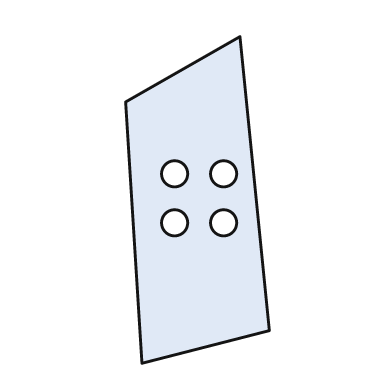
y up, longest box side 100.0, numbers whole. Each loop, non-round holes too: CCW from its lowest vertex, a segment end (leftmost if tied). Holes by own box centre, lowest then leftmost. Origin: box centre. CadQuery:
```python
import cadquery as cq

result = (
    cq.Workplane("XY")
    .moveTo(-17.0, -50.0)
    .lineTo(22.0, -40.0)
    .lineTo(13.0, 50.0)
    .lineTo(-22.0, 30.0)
    .close()
    .moveTo(-7.0, -7.0)
    .circle(4.0)
    .moveTo(8.0, -7.0)
    .circle(4.0)
    .moveTo(-7.0, 8.0)
    .circle(4.0)
    .moveTo(8.0, 8.0)
    .circle(4.0)
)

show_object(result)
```